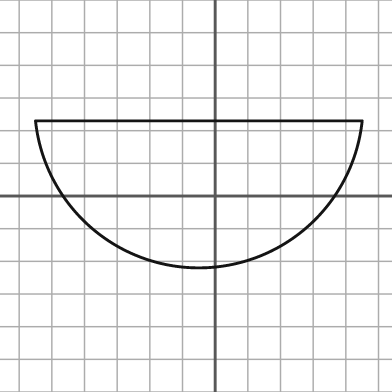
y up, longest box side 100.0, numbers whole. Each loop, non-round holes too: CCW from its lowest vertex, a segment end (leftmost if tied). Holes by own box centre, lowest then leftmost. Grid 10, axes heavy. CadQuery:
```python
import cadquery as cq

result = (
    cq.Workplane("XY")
    .moveTo(-55.0, 23.0)
    .threePointArc((-5.0, -22.0), (45.0, 23.0))
    .close()
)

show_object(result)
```